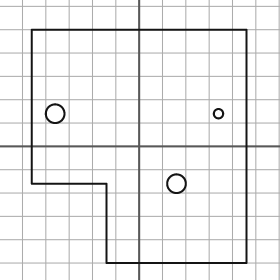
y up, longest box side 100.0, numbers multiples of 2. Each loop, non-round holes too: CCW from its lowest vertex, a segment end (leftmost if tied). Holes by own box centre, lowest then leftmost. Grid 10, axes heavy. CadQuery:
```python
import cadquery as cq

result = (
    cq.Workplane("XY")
    .moveTo(-14.0, -50.0)
    .lineTo(46.0, -50.0)
    .lineTo(46.0, 50.0)
    .lineTo(-46.0, 50.0)
    .lineTo(-46.0, -16.0)
    .lineTo(-14.0, -16.0)
    .close()
    .moveTo(16.0, -16.0)
    .circle(4.0)
    .moveTo(-36.0, 14.0)
    .circle(4.0)
    .moveTo(34.0, 14.0)
    .circle(2.0)
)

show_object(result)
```